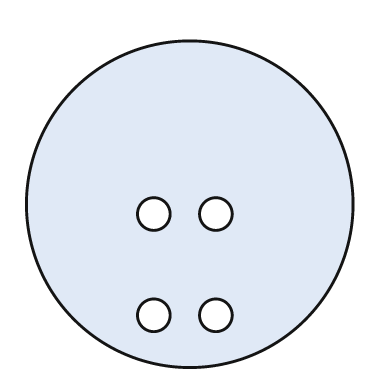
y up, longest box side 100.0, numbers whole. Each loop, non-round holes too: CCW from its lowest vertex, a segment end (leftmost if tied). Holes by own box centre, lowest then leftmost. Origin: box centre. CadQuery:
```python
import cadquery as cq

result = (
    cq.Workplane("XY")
    .moveTo(0.0, 0.0)
    .circle(50.0)
    .moveTo(-11.0, -34.0)
    .circle(5.0)
    .moveTo(8.0, -34.0)
    .circle(5.0)
    .moveTo(-11.0, -3.0)
    .circle(5.0)
    .moveTo(8.0, -3.0)
    .circle(5.0)
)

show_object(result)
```